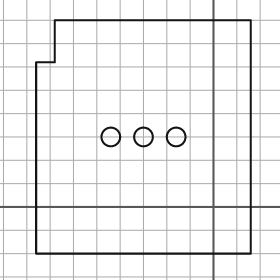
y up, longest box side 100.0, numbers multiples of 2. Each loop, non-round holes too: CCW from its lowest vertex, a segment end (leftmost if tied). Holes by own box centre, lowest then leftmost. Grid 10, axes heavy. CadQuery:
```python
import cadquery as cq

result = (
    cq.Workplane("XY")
    .moveTo(-76.0, -20.0)
    .lineTo(16.0, -20.0)
    .lineTo(16.0, 80.0)
    .lineTo(-68.0, 80.0)
    .lineTo(-68.0, 62.0)
    .lineTo(-76.0, 62.0)
    .close()
    .moveTo(-44.0, 30.0)
    .circle(4.0)
    .moveTo(-30.0, 30.0)
    .circle(4.0)
    .moveTo(-16.0, 30.0)
    .circle(4.0)
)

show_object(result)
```